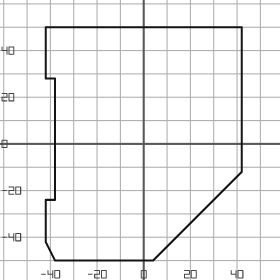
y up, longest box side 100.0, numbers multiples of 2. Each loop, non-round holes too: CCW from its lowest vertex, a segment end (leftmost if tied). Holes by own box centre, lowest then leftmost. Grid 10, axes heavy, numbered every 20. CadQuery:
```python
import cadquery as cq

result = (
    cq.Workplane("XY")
    .moveTo(-38.0, -50.0)
    .lineTo(4.0, -50.0)
    .lineTo(42.0, -12.0)
    .lineTo(42.0, 50.0)
    .lineTo(-42.0, 50.0)
    .lineTo(-42.0, 28.0)
    .lineTo(-38.0, 28.0)
    .lineTo(-38.0, -24.0)
    .lineTo(-42.0, -24.0)
    .lineTo(-42.0, -42.0)
    .close()
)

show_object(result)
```